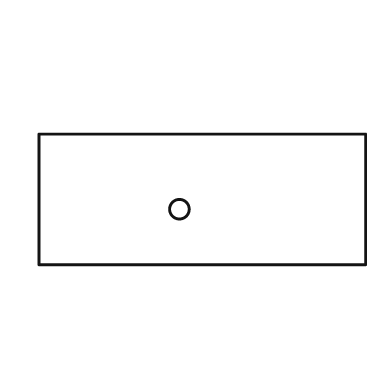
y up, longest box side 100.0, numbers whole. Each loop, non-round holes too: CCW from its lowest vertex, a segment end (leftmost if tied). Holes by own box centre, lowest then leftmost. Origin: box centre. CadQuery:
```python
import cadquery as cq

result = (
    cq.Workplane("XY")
    .moveTo(-50.0, -20.0)
    .lineTo(50.0, -20.0)
    .lineTo(50.0, 20.0)
    .lineTo(-50.0, 20.0)
    .close()
    .moveTo(-7.0, -3.0)
    .circle(3.0)
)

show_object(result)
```